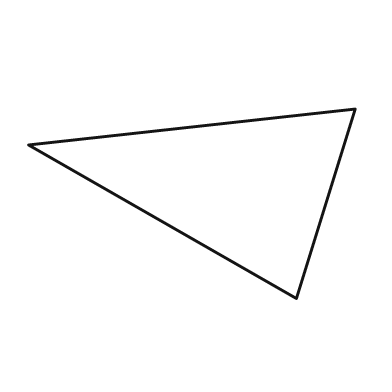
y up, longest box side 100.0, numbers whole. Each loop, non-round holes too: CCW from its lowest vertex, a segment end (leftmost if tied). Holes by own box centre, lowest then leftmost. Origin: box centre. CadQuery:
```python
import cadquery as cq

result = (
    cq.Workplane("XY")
    .moveTo(32.0, -29.0)
    .lineTo(50.0, 29.0)
    .lineTo(-50.0, 18.0)
    .close()
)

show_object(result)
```